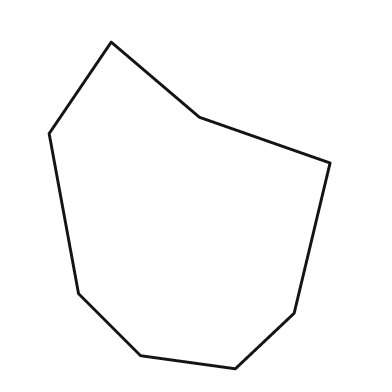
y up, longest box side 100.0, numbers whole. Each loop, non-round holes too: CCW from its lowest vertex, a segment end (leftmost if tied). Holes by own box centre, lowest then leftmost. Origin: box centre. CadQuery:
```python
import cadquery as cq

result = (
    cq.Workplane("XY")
    .moveTo(14.0, -50.0)
    .lineTo(32.0, -33.0)
    .lineTo(43.0, 13.0)
    .lineTo(3.0, 27.0)
    .lineTo(-24.0, 50.0)
    .lineTo(-43.0, 22.0)
    .lineTo(-34.0, -27.0)
    .lineTo(-15.0, -46.0)
    .close()
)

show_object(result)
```